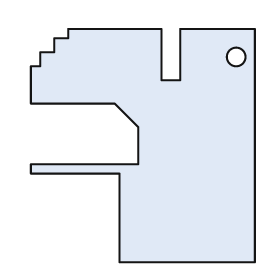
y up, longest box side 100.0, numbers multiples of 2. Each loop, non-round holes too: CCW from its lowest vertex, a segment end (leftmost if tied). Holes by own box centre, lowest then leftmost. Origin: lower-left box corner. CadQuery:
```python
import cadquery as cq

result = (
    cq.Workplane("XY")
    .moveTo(38.0, 0.0)
    .lineTo(96.0, 0.0)
    .lineTo(96.0, 100.0)
    .lineTo(64.0, 100.0)
    .lineTo(64.0, 78.0)
    .lineTo(56.0, 78.0)
    .lineTo(56.0, 100.0)
    .lineTo(16.0, 100.0)
    .lineTo(16.0, 96.0)
    .lineTo(10.0, 96.0)
    .lineTo(10.0, 90.0)
    .lineTo(4.0, 90.0)
    .lineTo(4.0, 84.0)
    .lineTo(0.0, 84.0)
    .lineTo(0.0, 68.0)
    .lineTo(36.0, 68.0)
    .lineTo(46.0, 58.0)
    .lineTo(46.0, 42.0)
    .lineTo(0.0, 42.0)
    .lineTo(0.0, 38.0)
    .lineTo(38.0, 38.0)
    .close()
    .moveTo(88.0, 88.0)
    .circle(4.0)
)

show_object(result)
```